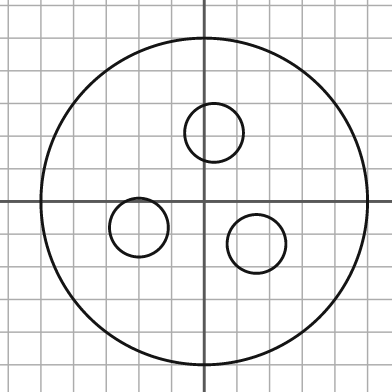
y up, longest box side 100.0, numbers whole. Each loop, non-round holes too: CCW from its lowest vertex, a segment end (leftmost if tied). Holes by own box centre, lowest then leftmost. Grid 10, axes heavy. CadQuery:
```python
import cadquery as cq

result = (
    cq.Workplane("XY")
    .moveTo(0.0, 0.0)
    .circle(50.0)
    .moveTo(16.0, -13.0)
    .circle(9.0)
    .moveTo(-20.0, -8.0)
    .circle(9.0)
    .moveTo(3.0, 21.0)
    .circle(9.0)
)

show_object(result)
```